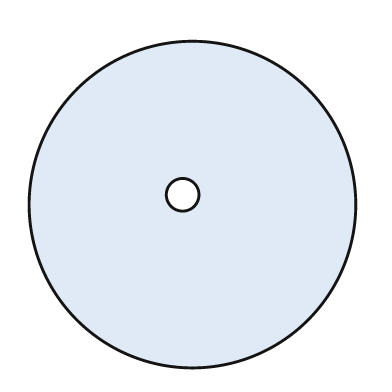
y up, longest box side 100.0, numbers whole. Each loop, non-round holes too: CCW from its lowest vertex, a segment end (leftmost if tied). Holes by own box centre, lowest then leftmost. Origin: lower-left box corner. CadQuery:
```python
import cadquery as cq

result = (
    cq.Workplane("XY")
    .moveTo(50.0, 50.0)
    .circle(50.0)
    .moveTo(47.0, 53.0)
    .circle(5.0)
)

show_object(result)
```